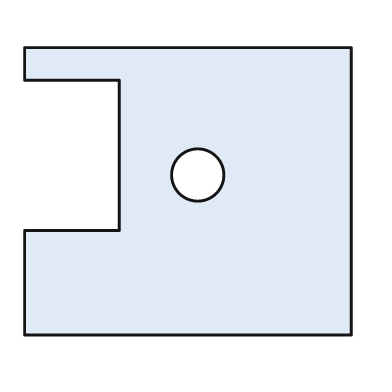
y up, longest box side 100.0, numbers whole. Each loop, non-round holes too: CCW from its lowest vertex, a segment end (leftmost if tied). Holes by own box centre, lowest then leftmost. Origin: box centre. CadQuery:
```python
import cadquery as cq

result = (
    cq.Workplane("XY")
    .moveTo(-50.0, -44.0)
    .lineTo(50.0, -44.0)
    .lineTo(50.0, 44.0)
    .lineTo(-50.0, 44.0)
    .lineTo(-50.0, 34.0)
    .lineTo(-21.0, 34.0)
    .lineTo(-21.0, -12.0)
    .lineTo(-50.0, -12.0)
    .close()
    .moveTo(3.0, 5.0)
    .circle(8.0)
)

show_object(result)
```